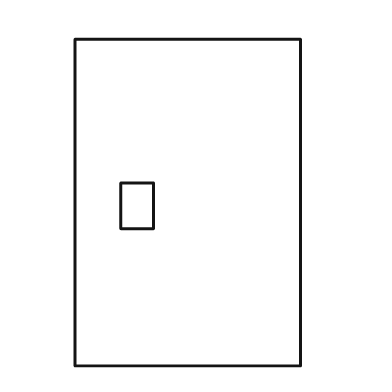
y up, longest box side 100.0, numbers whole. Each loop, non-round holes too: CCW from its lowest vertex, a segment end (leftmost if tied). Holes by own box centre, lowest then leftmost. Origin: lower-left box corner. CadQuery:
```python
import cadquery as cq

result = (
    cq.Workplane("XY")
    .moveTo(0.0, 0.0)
    .lineTo(69.0, 0.0)
    .lineTo(69.0, 100.0)
    .lineTo(0.0, 100.0)
    .close()
    .moveTo(14.0, 42.0)
    .lineTo(24.0, 42.0)
    .lineTo(24.0, 56.0)
    .lineTo(14.0, 56.0)
    .close()
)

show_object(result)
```